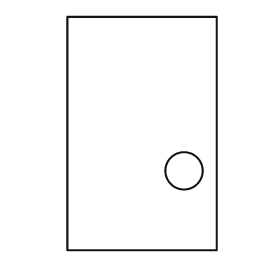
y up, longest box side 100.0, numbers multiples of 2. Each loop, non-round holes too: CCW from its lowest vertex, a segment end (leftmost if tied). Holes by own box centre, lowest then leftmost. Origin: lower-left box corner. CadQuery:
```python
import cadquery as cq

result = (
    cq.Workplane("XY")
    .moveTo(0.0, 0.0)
    .lineTo(64.0, 0.0)
    .lineTo(64.0, 100.0)
    .lineTo(0.0, 100.0)
    .close()
    .moveTo(50.0, 34.0)
    .circle(8.0)
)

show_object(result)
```